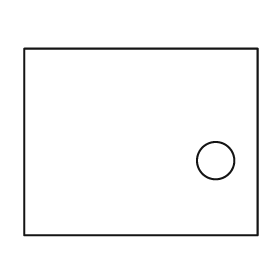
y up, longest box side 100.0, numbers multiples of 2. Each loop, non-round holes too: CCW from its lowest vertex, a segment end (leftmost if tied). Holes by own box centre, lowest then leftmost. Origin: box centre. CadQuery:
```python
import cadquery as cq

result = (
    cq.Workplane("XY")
    .moveTo(-50.0, -40.0)
    .lineTo(50.0, -40.0)
    .lineTo(50.0, 40.0)
    .lineTo(-50.0, 40.0)
    .close()
    .moveTo(32.0, -8.0)
    .circle(8.0)
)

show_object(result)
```